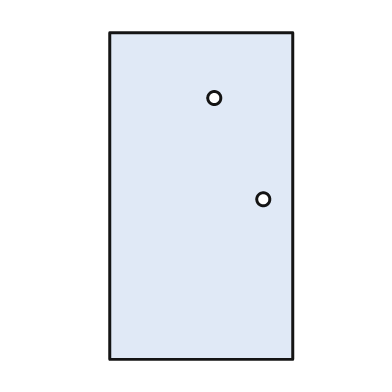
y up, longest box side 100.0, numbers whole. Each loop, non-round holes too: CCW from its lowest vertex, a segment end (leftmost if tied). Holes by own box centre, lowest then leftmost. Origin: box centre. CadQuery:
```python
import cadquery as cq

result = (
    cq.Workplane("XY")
    .moveTo(-28.0, -50.0)
    .lineTo(28.0, -50.0)
    .lineTo(28.0, 50.0)
    .lineTo(-28.0, 50.0)
    .close()
    .moveTo(19.0, -1.0)
    .circle(2.0)
    .moveTo(4.0, 30.0)
    .circle(2.0)
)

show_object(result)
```